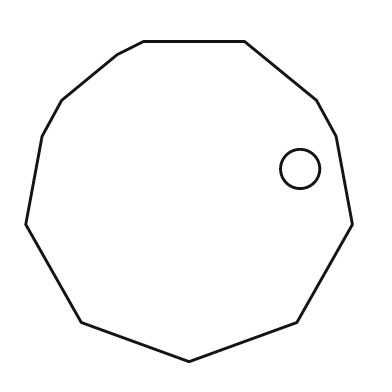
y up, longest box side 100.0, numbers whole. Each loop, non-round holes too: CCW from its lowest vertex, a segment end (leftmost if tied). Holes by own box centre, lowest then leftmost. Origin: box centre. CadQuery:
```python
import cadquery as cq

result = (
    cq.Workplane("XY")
    .moveTo(0.0, -49.0)
    .lineTo(33.0, -37.0)
    .lineTo(50.0, -7.0)
    .lineTo(45.0, 20.0)
    .lineTo(39.0, 31.0)
    .lineTo(17.0, 49.0)
    .lineTo(-14.0, 49.0)
    .lineTo(-22.0, 45.0)
    .lineTo(-39.0, 31.0)
    .lineTo(-45.0, 20.0)
    .lineTo(-50.0, -7.0)
    .lineTo(-33.0, -37.0)
    .close()
    .moveTo(34.0, 10.0)
    .circle(6.0)
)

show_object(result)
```